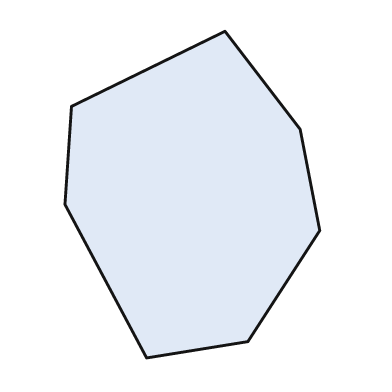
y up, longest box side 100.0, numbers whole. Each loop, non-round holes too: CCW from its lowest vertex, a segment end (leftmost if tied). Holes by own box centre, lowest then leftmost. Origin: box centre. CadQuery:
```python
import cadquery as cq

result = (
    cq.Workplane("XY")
    .moveTo(-14.0, -50.0)
    .lineTo(17.0, -45.0)
    .lineTo(39.0, -11.0)
    .lineTo(33.0, 20.0)
    .lineTo(10.0, 50.0)
    .lineTo(-37.0, 27.0)
    .lineTo(-39.0, -3.0)
    .close()
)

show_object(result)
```